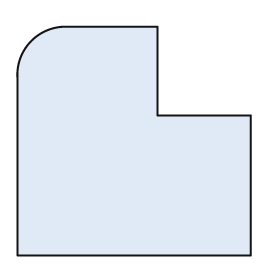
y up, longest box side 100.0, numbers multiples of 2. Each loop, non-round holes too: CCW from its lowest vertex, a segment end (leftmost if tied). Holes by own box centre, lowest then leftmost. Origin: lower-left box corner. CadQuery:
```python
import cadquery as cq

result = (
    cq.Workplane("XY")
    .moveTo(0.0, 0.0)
    .lineTo(100.0, 0.0)
    .lineTo(100.0, 60.0)
    .lineTo(60.0, 60.0)
    .lineTo(60.0, 98.0)
    .lineTo(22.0, 98.0)
    .threePointArc((6.0, 92.0), (0.0, 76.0))
    .close()
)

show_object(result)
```